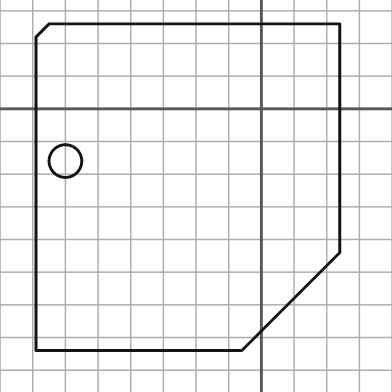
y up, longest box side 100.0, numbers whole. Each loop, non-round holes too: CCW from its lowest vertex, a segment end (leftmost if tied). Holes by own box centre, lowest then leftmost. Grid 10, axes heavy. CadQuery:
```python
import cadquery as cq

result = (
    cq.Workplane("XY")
    .moveTo(-69.0, -74.0)
    .lineTo(-6.0, -74.0)
    .lineTo(24.0, -44.0)
    .lineTo(24.0, 26.0)
    .lineTo(-65.0, 26.0)
    .lineTo(-69.0, 22.0)
    .close()
    .moveTo(-60.0, -16.0)
    .circle(5.0)
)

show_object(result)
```